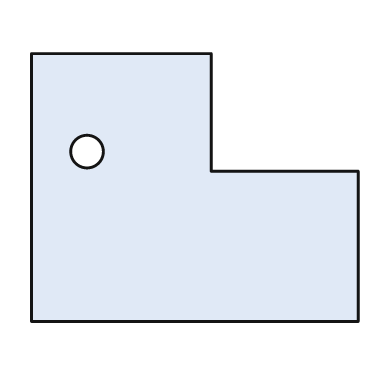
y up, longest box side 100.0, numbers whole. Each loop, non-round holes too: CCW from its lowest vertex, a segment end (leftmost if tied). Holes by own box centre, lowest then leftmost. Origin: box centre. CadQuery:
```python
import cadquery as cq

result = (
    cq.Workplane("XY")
    .moveTo(-50.0, -41.0)
    .lineTo(50.0, -41.0)
    .lineTo(50.0, 5.0)
    .lineTo(5.0, 5.0)
    .lineTo(5.0, 41.0)
    .lineTo(-50.0, 41.0)
    .close()
    .moveTo(-33.0, 11.0)
    .circle(5.0)
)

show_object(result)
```